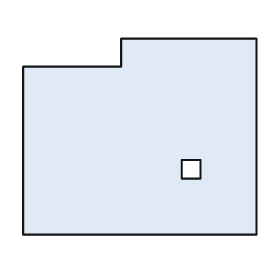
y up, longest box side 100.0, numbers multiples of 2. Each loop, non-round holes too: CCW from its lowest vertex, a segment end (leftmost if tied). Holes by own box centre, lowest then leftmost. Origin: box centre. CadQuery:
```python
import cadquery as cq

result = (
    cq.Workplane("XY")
    .moveTo(-50.0, -42.0)
    .lineTo(50.0, -42.0)
    .lineTo(50.0, 42.0)
    .lineTo(-8.0, 42.0)
    .lineTo(-8.0, 30.0)
    .lineTo(-50.0, 30.0)
    .close()
    .moveTo(18.0, -18.0)
    .lineTo(26.0, -18.0)
    .lineTo(26.0, -10.0)
    .lineTo(18.0, -10.0)
    .close()
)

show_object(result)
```